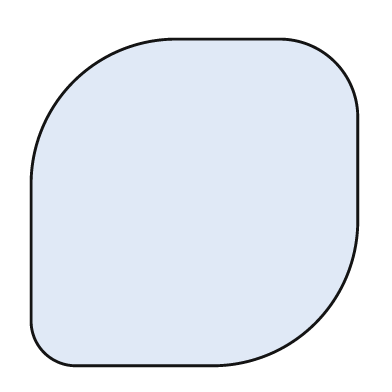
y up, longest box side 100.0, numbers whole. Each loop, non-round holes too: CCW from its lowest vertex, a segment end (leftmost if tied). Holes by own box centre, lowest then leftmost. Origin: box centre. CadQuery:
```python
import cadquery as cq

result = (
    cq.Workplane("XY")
    .moveTo(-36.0, -50.0)
    .lineTo(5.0, -50.0)
    .threePointArc((37.0, -37.0), (50.0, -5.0))
    .lineTo(50.0, 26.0)
    .threePointArc((43.0, 43.0), (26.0, 50.0))
    .lineTo(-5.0, 50.0)
    .threePointArc((-37.0, 37.0), (-50.0, 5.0))
    .lineTo(-50.0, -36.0)
    .threePointArc((-46.0, -46.0), (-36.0, -50.0))
    .close()
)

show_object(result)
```